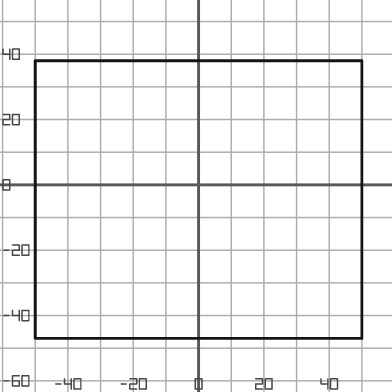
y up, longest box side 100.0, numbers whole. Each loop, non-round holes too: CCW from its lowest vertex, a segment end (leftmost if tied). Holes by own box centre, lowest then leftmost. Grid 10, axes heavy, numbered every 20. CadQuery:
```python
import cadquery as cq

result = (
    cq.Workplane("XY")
    .moveTo(-50.0, -47.0)
    .lineTo(50.0, -47.0)
    .lineTo(50.0, 38.0)
    .lineTo(-50.0, 38.0)
    .close()
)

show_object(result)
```